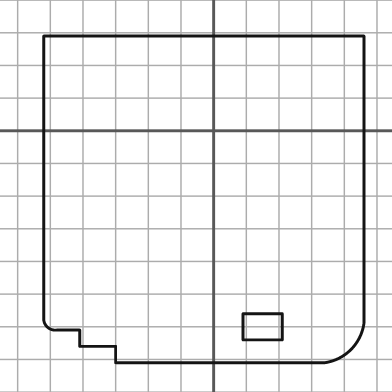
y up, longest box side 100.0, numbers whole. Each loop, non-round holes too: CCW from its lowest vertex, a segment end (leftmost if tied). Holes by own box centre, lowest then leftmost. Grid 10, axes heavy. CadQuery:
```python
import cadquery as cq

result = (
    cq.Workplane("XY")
    .moveTo(-30.0, -71.0)
    .lineTo(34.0, -71.0)
    .threePointArc((42.0, -67.0), (46.0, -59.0))
    .lineTo(46.0, 29.0)
    .lineTo(-52.0, 29.0)
    .lineTo(-52.0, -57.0)
    .threePointArc((-51.0, -60.0), (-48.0, -61.0))
    .lineTo(-41.0, -61.0)
    .lineTo(-41.0, -66.0)
    .lineTo(-30.0, -66.0)
    .close()
    .moveTo(9.0, -64.0)
    .lineTo(21.0, -64.0)
    .lineTo(21.0, -56.0)
    .lineTo(9.0, -56.0)
    .close()
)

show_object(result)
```